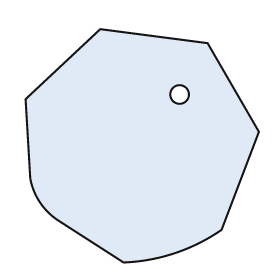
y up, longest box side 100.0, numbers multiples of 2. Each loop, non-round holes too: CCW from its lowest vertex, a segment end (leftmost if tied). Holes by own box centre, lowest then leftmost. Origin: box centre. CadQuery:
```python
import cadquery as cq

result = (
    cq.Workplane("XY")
    .moveTo(-8.0, -50.0)
    .threePointArc((14.0, -46.0), (34.0, -36.0))
    .lineTo(50.0, 6.0)
    .lineTo(28.0, 44.0)
    .lineTo(-18.0, 50.0)
    .lineTo(-50.0, 20.0)
    .lineTo(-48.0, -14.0)
    .threePointArc((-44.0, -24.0), (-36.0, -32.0))
    .close()
    .moveTo(16.0, 22.0)
    .circle(4.0)
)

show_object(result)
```